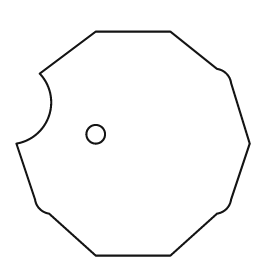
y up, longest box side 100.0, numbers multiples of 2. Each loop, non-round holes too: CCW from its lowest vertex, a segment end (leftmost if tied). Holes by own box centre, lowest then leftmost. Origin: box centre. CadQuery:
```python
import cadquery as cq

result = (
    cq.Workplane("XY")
    .moveTo(-16.0, -48.0)
    .lineTo(16.0, -48.0)
    .lineTo(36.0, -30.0)
    .threePointArc((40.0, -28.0), (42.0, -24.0))
    .lineTo(50.0, 0.0)
    .lineTo(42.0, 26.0)
    .threePointArc((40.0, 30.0), (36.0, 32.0))
    .lineTo(16.0, 48.0)
    .lineTo(-16.0, 48.0)
    .lineTo(-40.0, 30.0)
    .threePointArc((-36.0, 12.0), (-50.0, 0.0))
    .lineTo(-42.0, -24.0)
    .threePointArc((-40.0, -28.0), (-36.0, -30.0))
    .close()
    .moveTo(-16.0, 4.0)
    .circle(4.0)
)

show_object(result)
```